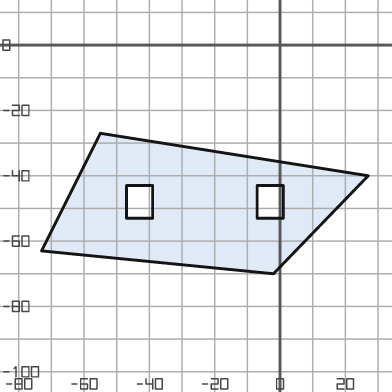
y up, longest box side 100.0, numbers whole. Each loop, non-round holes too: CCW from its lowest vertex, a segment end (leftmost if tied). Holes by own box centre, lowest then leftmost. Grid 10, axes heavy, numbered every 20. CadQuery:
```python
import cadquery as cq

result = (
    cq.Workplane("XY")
    .moveTo(-2.0, -70.0)
    .lineTo(27.0, -40.0)
    .lineTo(-55.0, -27.0)
    .lineTo(-73.0, -63.0)
    .close()
    .moveTo(-47.0, -53.0)
    .lineTo(-39.0, -53.0)
    .lineTo(-39.0, -43.0)
    .lineTo(-47.0, -43.0)
    .close()
    .moveTo(-7.0, -53.0)
    .lineTo(1.0, -53.0)
    .lineTo(1.0, -43.0)
    .lineTo(-7.0, -43.0)
    .close()
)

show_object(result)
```